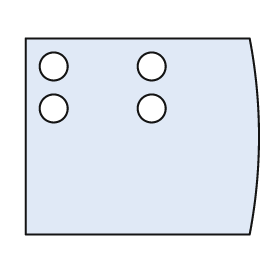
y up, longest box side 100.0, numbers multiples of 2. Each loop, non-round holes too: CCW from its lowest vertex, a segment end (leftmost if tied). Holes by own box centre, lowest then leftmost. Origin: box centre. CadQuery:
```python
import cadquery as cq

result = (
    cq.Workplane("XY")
    .moveTo(-50.0, -42.0)
    .lineTo(46.0, -42.0)
    .threePointArc((50.0, 0.0), (46.0, 42.0))
    .lineTo(-50.0, 42.0)
    .close()
    .moveTo(-38.0, 12.0)
    .circle(6.0)
    .moveTo(4.0, 12.0)
    .circle(6.0)
    .moveTo(-38.0, 30.0)
    .circle(6.0)
    .moveTo(4.0, 30.0)
    .circle(6.0)
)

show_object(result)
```